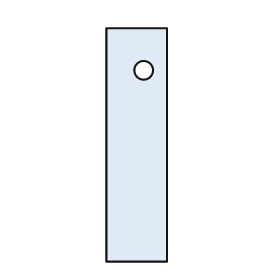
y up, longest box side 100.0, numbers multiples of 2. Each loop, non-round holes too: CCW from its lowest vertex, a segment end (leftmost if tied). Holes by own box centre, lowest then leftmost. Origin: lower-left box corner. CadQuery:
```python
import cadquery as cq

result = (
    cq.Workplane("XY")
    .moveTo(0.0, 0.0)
    .lineTo(26.0, 0.0)
    .lineTo(26.0, 100.0)
    .lineTo(0.0, 100.0)
    .close()
    .moveTo(16.0, 82.0)
    .circle(4.0)
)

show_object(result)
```